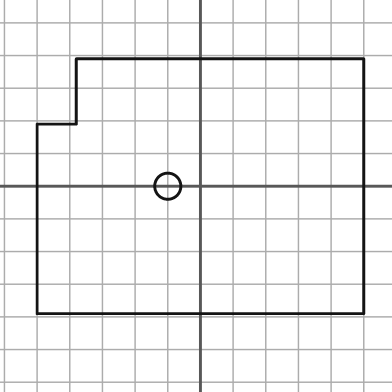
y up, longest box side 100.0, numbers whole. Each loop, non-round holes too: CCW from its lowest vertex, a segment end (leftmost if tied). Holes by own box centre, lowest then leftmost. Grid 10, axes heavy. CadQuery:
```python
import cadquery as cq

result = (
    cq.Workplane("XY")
    .moveTo(-50.0, -39.0)
    .lineTo(50.0, -39.0)
    .lineTo(50.0, 39.0)
    .lineTo(-38.0, 39.0)
    .lineTo(-38.0, 19.0)
    .lineTo(-50.0, 19.0)
    .close()
    .moveTo(-10.0, 0.0)
    .circle(4.0)
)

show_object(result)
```